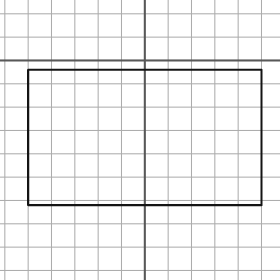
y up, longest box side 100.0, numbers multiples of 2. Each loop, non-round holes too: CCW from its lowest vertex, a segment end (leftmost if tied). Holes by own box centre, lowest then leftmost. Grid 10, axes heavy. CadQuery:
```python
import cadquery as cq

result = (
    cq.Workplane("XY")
    .moveTo(-50.0, -62.0)
    .lineTo(50.0, -62.0)
    .lineTo(50.0, -4.0)
    .lineTo(-50.0, -4.0)
    .close()
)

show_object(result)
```